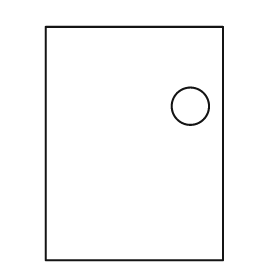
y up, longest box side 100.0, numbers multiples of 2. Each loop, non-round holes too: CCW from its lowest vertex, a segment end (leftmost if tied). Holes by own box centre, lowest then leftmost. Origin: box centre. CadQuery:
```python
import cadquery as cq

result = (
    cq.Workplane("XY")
    .moveTo(-38.0, -50.0)
    .lineTo(38.0, -50.0)
    .lineTo(38.0, 50.0)
    .lineTo(-38.0, 50.0)
    .close()
    .moveTo(24.0, 16.0)
    .circle(8.0)
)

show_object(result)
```